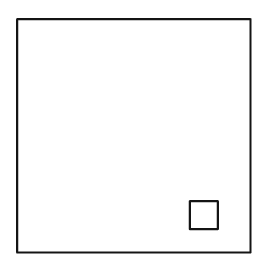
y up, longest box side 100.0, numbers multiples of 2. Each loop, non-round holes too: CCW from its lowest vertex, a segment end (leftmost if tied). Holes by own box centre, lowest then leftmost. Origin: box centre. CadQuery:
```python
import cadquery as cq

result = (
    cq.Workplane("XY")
    .moveTo(-50.0, -50.0)
    .lineTo(50.0, -50.0)
    .lineTo(50.0, 50.0)
    .lineTo(-50.0, 50.0)
    .close()
    .moveTo(24.0, -40.0)
    .lineTo(36.0, -40.0)
    .lineTo(36.0, -28.0)
    .lineTo(24.0, -28.0)
    .close()
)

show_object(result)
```